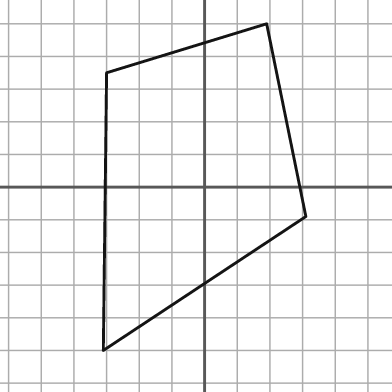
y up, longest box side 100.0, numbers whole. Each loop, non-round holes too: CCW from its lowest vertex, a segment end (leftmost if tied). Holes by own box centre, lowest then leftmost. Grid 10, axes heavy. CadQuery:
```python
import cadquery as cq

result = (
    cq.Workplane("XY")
    .moveTo(-31.0, -50.0)
    .lineTo(31.0, -9.0)
    .lineTo(19.0, 50.0)
    .lineTo(-30.0, 35.0)
    .close()
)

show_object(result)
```